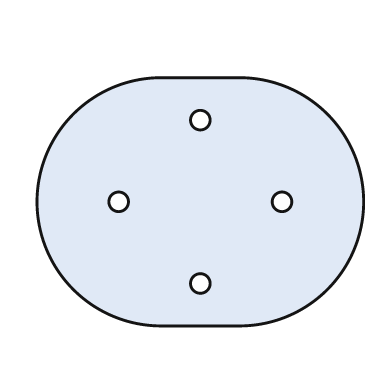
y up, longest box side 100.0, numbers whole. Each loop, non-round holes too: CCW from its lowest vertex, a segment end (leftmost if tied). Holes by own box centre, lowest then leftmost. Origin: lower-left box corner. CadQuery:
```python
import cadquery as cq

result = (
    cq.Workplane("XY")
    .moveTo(38.0, 0.0)
    .lineTo(62.0, 0.0)
    .threePointArc((100.0, 38.0), (62.0, 76.0))
    .lineTo(38.0, 76.0)
    .threePointArc((0.0, 38.0), (38.0, 0.0))
    .close()
    .moveTo(50.0, 13.0)
    .circle(3.0)
    .moveTo(25.0, 38.0)
    .circle(3.0)
    .moveTo(75.0, 38.0)
    .circle(3.0)
    .moveTo(50.0, 63.0)
    .circle(3.0)
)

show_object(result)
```